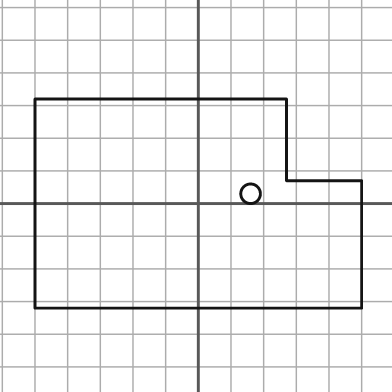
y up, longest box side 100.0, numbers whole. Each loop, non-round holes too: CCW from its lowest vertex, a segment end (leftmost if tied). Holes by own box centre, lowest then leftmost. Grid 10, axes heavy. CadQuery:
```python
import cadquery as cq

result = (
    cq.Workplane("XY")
    .moveTo(-50.0, -32.0)
    .lineTo(50.0, -32.0)
    .lineTo(50.0, 7.0)
    .lineTo(27.0, 7.0)
    .lineTo(27.0, 32.0)
    .lineTo(-50.0, 32.0)
    .close()
    .moveTo(16.0, 3.0)
    .circle(3.0)
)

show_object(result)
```